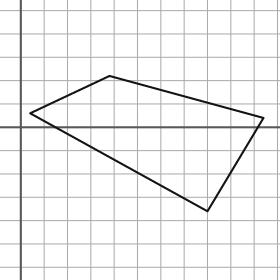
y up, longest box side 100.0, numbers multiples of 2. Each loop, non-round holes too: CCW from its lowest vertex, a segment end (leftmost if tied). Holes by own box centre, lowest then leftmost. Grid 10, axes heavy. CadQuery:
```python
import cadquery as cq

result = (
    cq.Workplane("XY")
    .moveTo(80.0, -36.0)
    .lineTo(104.0, 4.0)
    .lineTo(38.0, 22.0)
    .lineTo(4.0, 6.0)
    .close()
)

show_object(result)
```